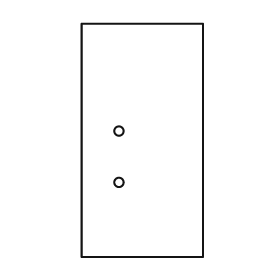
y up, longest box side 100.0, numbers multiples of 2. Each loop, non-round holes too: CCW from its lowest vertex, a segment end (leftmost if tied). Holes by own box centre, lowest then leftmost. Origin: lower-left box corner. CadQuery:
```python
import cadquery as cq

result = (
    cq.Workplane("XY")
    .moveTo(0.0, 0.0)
    .lineTo(52.0, 0.0)
    .lineTo(52.0, 100.0)
    .lineTo(0.0, 100.0)
    .close()
    .moveTo(16.0, 32.0)
    .circle(2.0)
    .moveTo(16.0, 54.0)
    .circle(2.0)
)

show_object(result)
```